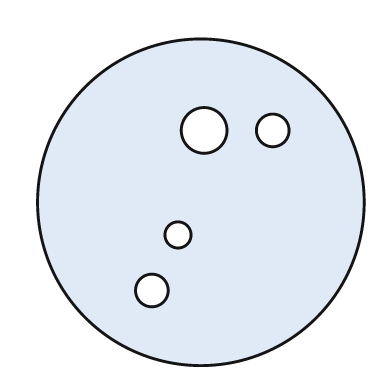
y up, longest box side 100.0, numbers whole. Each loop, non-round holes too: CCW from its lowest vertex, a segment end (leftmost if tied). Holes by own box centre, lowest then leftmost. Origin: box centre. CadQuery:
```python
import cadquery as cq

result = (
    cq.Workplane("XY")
    .moveTo(0.0, 0.0)
    .circle(50.0)
    .moveTo(-15.0, -27.0)
    .circle(5.0)
    .moveTo(-7.0, -10.0)
    .circle(4.0)
    .moveTo(1.0, 22.0)
    .circle(7.0)
    .moveTo(22.0, 22.0)
    .circle(5.0)
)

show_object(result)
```